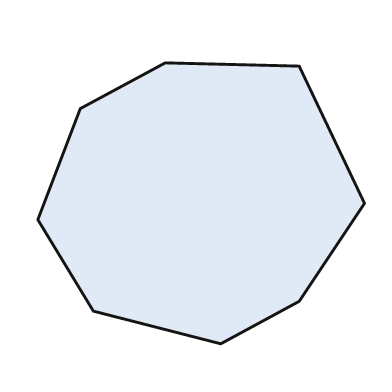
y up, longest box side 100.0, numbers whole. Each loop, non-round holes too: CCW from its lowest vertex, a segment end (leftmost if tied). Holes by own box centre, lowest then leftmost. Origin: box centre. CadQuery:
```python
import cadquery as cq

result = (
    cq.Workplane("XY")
    .moveTo(6.0, -43.0)
    .lineTo(30.0, -30.0)
    .lineTo(50.0, 0.0)
    .lineTo(30.0, 42.0)
    .lineTo(-11.0, 43.0)
    .lineTo(-37.0, 29.0)
    .lineTo(-50.0, -5.0)
    .lineTo(-33.0, -33.0)
    .close()
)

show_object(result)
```